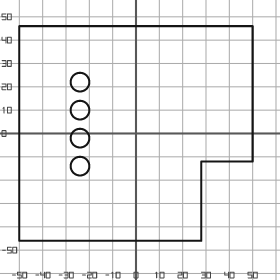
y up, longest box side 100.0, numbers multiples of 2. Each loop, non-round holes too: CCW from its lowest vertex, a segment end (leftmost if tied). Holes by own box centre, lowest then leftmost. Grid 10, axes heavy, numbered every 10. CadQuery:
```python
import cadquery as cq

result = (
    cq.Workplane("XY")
    .moveTo(-50.0, -46.0)
    .lineTo(28.0, -46.0)
    .lineTo(28.0, -12.0)
    .lineTo(50.0, -12.0)
    .lineTo(50.0, 46.0)
    .lineTo(-50.0, 46.0)
    .close()
    .moveTo(-24.0, -14.0)
    .circle(4.0)
    .moveTo(-24.0, -2.0)
    .circle(4.0)
    .moveTo(-24.0, 10.0)
    .circle(4.0)
    .moveTo(-24.0, 22.0)
    .circle(4.0)
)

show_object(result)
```